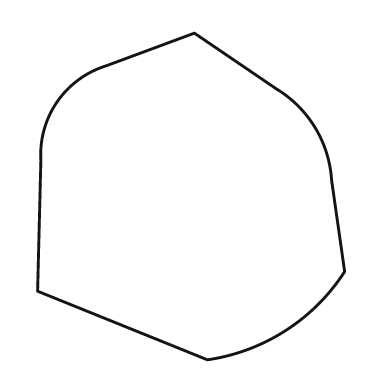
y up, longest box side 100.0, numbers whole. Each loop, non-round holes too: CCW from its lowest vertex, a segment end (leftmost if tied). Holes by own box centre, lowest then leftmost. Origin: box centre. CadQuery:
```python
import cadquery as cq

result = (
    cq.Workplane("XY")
    .moveTo(5.0, -50.0)
    .threePointArc((29.0, -41.0), (47.0, -23.0))
    .lineTo(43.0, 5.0)
    .threePointArc((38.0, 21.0), (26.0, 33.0))
    .lineTo(1.0, 50.0)
    .lineTo(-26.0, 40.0)
    .threePointArc((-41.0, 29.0), (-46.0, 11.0))
    .lineTo(-47.0, -29.0)
    .close()
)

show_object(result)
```